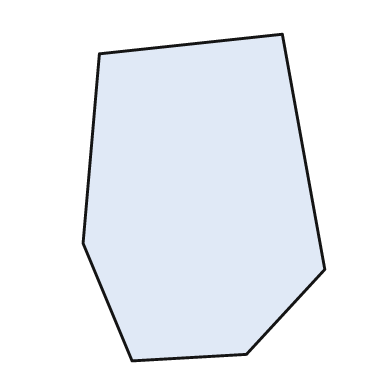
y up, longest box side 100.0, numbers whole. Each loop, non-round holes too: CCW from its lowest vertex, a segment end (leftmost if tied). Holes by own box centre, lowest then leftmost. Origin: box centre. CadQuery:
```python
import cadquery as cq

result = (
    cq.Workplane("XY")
    .moveTo(-22.0, -50.0)
    .lineTo(13.0, -48.0)
    .lineTo(37.0, -22.0)
    .lineTo(24.0, 50.0)
    .lineTo(-32.0, 44.0)
    .lineTo(-37.0, -14.0)
    .close()
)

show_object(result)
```